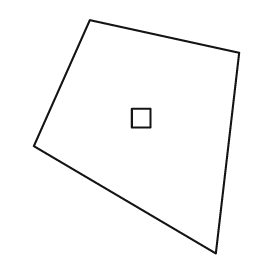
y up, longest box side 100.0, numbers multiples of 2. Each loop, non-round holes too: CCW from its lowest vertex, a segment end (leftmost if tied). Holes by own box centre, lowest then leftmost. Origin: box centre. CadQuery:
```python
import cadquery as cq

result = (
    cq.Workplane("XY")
    .moveTo(34.0, -50.0)
    .lineTo(44.0, 36.0)
    .lineTo(-20.0, 50.0)
    .lineTo(-44.0, -4.0)
    .close()
    .moveTo(-2.0, 4.0)
    .lineTo(6.0, 4.0)
    .lineTo(6.0, 12.0)
    .lineTo(-2.0, 12.0)
    .close()
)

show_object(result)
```